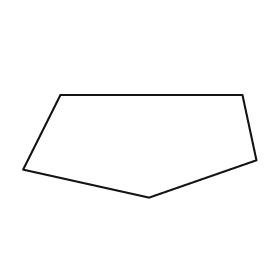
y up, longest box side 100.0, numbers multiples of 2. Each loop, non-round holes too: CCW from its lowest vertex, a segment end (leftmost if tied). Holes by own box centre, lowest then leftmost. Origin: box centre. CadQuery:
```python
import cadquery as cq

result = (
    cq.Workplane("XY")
    .moveTo(4.0, -22.0)
    .lineTo(50.0, -6.0)
    .lineTo(44.0, 22.0)
    .lineTo(-34.0, 22.0)
    .lineTo(-50.0, -10.0)
    .close()
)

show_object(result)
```